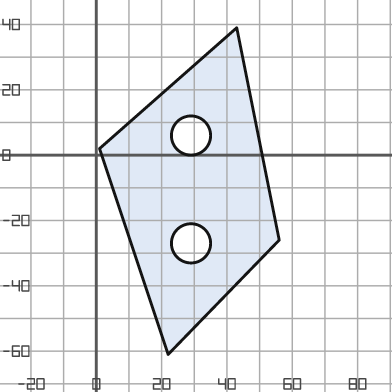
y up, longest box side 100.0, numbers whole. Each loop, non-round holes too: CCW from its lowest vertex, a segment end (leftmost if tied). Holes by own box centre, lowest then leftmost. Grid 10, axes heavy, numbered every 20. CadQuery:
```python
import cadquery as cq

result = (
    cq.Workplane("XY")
    .moveTo(22.0, -61.0)
    .lineTo(56.0, -26.0)
    .lineTo(43.0, 39.0)
    .lineTo(1.0, 2.0)
    .close()
    .moveTo(29.0, -27.0)
    .circle(6.0)
    .moveTo(29.0, 6.0)
    .circle(6.0)
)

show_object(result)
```